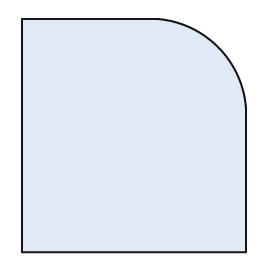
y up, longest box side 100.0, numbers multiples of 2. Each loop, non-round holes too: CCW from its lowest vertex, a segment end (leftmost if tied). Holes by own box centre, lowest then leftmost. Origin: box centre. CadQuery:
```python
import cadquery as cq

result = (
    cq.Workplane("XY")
    .moveTo(-48.0, -50.0)
    .lineTo(48.0, -50.0)
    .lineTo(48.0, 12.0)
    .threePointArc((36.0, 38.0), (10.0, 50.0))
    .lineTo(-48.0, 50.0)
    .close()
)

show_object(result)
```